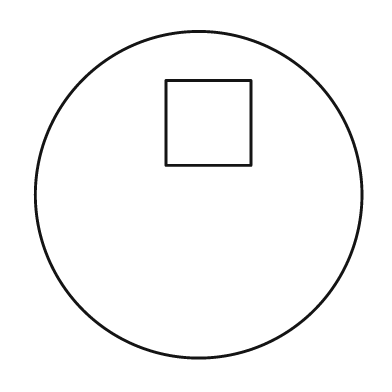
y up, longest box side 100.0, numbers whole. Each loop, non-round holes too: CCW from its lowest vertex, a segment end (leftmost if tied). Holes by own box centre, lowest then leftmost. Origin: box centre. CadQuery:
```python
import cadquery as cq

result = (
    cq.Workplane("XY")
    .moveTo(0.0, 0.0)
    .circle(50.0)
    .moveTo(-10.0, 9.0)
    .lineTo(16.0, 9.0)
    .lineTo(16.0, 35.0)
    .lineTo(-10.0, 35.0)
    .close()
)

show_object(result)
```